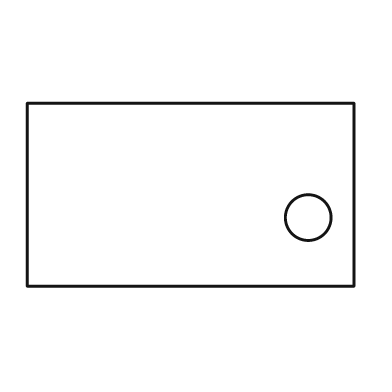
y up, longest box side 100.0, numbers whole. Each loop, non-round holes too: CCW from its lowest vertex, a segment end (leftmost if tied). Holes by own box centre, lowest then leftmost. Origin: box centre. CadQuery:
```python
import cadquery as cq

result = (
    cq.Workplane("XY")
    .moveTo(-50.0, -28.0)
    .lineTo(50.0, -28.0)
    .lineTo(50.0, 28.0)
    .lineTo(-50.0, 28.0)
    .close()
    .moveTo(36.0, -7.0)
    .circle(7.0)
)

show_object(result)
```